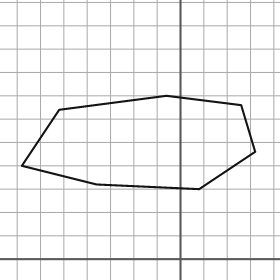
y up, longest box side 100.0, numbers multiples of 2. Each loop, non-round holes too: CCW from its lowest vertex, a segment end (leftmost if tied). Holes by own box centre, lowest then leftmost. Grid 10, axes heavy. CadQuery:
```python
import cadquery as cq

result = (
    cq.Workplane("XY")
    .moveTo(8.0, 30.0)
    .lineTo(32.0, 46.0)
    .lineTo(26.0, 66.0)
    .lineTo(-6.0, 70.0)
    .lineTo(-52.0, 64.0)
    .lineTo(-68.0, 40.0)
    .lineTo(-36.0, 32.0)
    .close()
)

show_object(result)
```